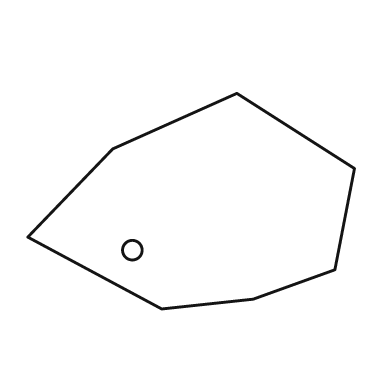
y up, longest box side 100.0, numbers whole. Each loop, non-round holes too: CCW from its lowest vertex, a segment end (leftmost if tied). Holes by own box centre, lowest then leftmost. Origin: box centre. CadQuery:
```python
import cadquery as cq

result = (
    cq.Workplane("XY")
    .moveTo(-9.0, -33.0)
    .lineTo(19.0, -30.0)
    .lineTo(44.0, -21.0)
    .lineTo(50.0, 10.0)
    .lineTo(14.0, 33.0)
    .lineTo(-24.0, 16.0)
    .lineTo(-50.0, -11.0)
    .close()
    .moveTo(-18.0, -15.0)
    .circle(3.0)
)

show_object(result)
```